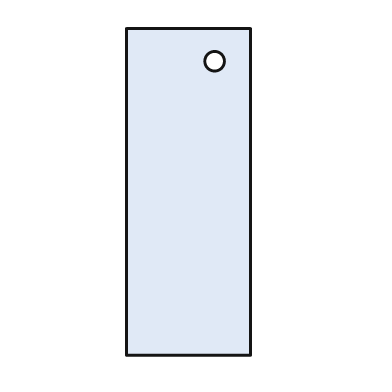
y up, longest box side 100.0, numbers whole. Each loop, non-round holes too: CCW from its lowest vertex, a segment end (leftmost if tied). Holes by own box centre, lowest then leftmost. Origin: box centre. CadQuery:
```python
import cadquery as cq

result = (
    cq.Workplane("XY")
    .moveTo(-19.0, -50.0)
    .lineTo(19.0, -50.0)
    .lineTo(19.0, 50.0)
    .lineTo(-19.0, 50.0)
    .close()
    .moveTo(8.0, 40.0)
    .circle(3.0)
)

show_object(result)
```